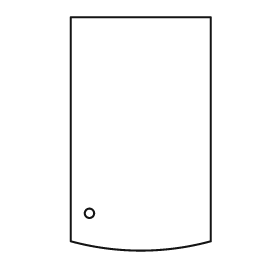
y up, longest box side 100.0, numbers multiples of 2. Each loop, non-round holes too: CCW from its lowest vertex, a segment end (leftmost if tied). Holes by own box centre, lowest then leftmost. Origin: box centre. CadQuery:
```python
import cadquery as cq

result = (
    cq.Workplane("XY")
    .moveTo(-30.0, -46.0)
    .threePointArc((0.0, -50.0), (30.0, -46.0))
    .lineTo(30.0, 50.0)
    .lineTo(-30.0, 50.0)
    .close()
    .moveTo(-22.0, -34.0)
    .circle(2.0)
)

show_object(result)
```